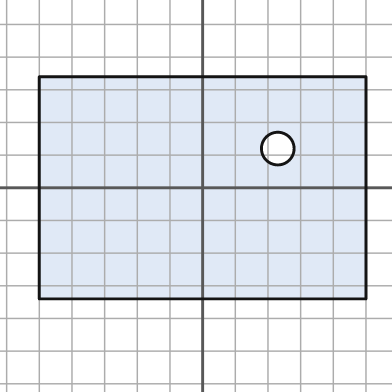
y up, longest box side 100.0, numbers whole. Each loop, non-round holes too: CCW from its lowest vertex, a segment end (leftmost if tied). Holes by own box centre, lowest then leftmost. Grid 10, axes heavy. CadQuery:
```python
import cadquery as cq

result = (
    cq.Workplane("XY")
    .moveTo(-50.0, -34.0)
    .lineTo(50.0, -34.0)
    .lineTo(50.0, 34.0)
    .lineTo(-50.0, 34.0)
    .close()
    .moveTo(23.0, 12.0)
    .circle(5.0)
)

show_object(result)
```